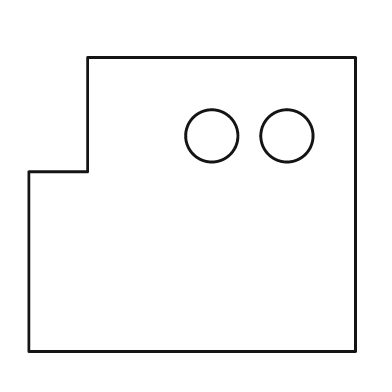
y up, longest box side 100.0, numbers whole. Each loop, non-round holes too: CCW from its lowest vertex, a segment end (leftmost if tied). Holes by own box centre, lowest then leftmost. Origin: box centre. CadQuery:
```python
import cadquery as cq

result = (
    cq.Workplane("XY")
    .moveTo(-50.0, -45.0)
    .lineTo(50.0, -45.0)
    .lineTo(50.0, 45.0)
    .lineTo(-32.0, 45.0)
    .lineTo(-32.0, 10.0)
    .lineTo(-50.0, 10.0)
    .close()
    .moveTo(6.0, 21.0)
    .circle(8.0)
    .moveTo(29.0, 21.0)
    .circle(8.0)
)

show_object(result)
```